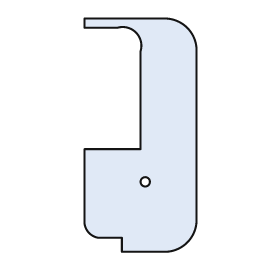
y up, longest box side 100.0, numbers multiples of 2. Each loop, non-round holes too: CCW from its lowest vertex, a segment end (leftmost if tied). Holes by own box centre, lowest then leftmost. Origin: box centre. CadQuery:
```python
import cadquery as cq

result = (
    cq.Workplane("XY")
    .moveTo(-8.0, -50.0)
    .lineTo(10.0, -50.0)
    .threePointArc((20.0, -46.0), (24.0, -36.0))
    .lineTo(24.0, 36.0)
    .threePointArc((20.0, 46.0), (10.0, 50.0))
    .lineTo(-24.0, 50.0)
    .lineTo(-24.0, 46.0)
    .lineTo(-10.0, 46.0)
    .threePointArc((-2.0, 44.0), (0.0, 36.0))
    .lineTo(0.0, -6.0)
    .lineTo(-24.0, -6.0)
    .lineTo(-24.0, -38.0)
    .threePointArc((-22.0, -42.0), (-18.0, -44.0))
    .lineTo(-8.0, -44.0)
    .close()
    .moveTo(2.0, -20.0)
    .circle(2.0)
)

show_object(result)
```